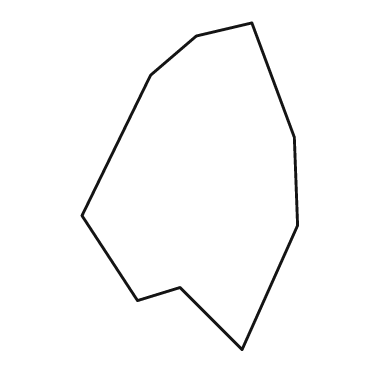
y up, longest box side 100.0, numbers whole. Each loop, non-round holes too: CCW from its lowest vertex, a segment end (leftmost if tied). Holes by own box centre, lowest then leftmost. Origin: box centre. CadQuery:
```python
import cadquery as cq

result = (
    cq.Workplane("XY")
    .moveTo(16.0, -50.0)
    .lineTo(33.0, -12.0)
    .lineTo(32.0, 15.0)
    .lineTo(19.0, 50.0)
    .lineTo(2.0, 46.0)
    .lineTo(-12.0, 34.0)
    .lineTo(-33.0, -9.0)
    .lineTo(-16.0, -35.0)
    .lineTo(-3.0, -31.0)
    .close()
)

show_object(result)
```